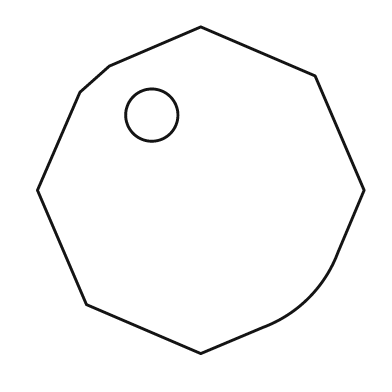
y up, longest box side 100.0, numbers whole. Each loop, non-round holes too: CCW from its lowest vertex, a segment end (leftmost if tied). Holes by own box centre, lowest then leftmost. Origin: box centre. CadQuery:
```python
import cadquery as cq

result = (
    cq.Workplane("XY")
    .moveTo(0.0, -50.0)
    .lineTo(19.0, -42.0)
    .threePointArc((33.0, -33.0), (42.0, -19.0))
    .lineTo(50.0, 0.0)
    .lineTo(35.0, 35.0)
    .lineTo(0.0, 50.0)
    .lineTo(-28.0, 38.0)
    .lineTo(-37.0, 30.0)
    .lineTo(-50.0, 0.0)
    .lineTo(-35.0, -35.0)
    .close()
    .moveTo(-15.0, 23.0)
    .circle(8.0)
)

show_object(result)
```